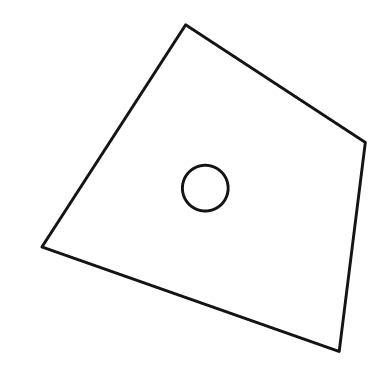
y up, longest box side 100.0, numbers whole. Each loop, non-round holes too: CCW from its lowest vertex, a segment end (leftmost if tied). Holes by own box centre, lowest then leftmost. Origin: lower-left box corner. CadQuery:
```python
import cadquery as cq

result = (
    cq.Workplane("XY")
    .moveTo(91.0, 0.0)
    .lineTo(99.0, 64.0)
    .lineTo(44.0, 100.0)
    .lineTo(0.0, 32.0)
    .close()
    .moveTo(50.0, 50.0)
    .circle(7.0)
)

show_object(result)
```